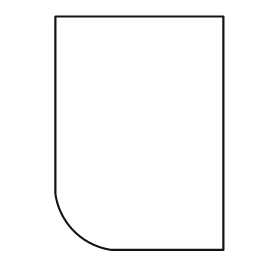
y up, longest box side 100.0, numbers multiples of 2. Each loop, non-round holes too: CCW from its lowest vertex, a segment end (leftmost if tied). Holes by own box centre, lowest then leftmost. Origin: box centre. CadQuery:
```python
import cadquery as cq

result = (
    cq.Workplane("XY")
    .moveTo(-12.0, -50.0)
    .lineTo(36.0, -50.0)
    .lineTo(36.0, 50.0)
    .lineTo(-36.0, 50.0)
    .lineTo(-36.0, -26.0)
    .threePointArc((-28.0, -42.0), (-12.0, -50.0))
    .close()
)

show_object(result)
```